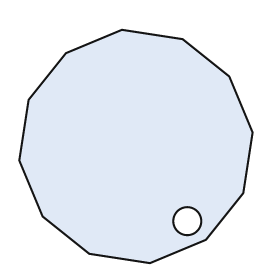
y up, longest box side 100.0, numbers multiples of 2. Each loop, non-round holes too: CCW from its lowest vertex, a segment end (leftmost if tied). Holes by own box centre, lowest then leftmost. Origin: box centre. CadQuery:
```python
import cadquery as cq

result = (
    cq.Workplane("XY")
    .moveTo(6.0, -50.0)
    .lineTo(30.0, -40.0)
    .lineTo(46.0, -20.0)
    .lineTo(50.0, 6.0)
    .lineTo(40.0, 30.0)
    .lineTo(20.0, 46.0)
    .lineTo(-6.0, 50.0)
    .lineTo(-30.0, 40.0)
    .lineTo(-46.0, 20.0)
    .lineTo(-50.0, -6.0)
    .lineTo(-40.0, -30.0)
    .lineTo(-20.0, -46.0)
    .close()
    .moveTo(22.0, -32.0)
    .circle(6.0)
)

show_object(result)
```